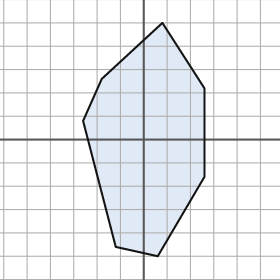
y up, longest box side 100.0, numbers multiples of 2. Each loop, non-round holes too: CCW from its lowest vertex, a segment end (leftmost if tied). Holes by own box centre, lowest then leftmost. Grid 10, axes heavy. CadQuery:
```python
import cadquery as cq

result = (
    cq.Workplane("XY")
    .moveTo(6.0, -50.0)
    .lineTo(26.0, -16.0)
    .lineTo(26.0, 22.0)
    .lineTo(8.0, 50.0)
    .lineTo(-18.0, 26.0)
    .lineTo(-26.0, 8.0)
    .lineTo(-12.0, -46.0)
    .close()
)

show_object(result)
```